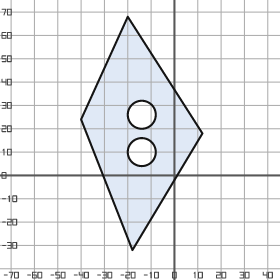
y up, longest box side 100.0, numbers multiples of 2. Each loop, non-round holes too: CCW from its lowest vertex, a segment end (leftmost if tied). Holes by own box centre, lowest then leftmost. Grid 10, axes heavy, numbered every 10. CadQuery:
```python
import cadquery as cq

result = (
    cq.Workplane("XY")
    .moveTo(-18.0, -32.0)
    .lineTo(12.0, 18.0)
    .lineTo(-20.0, 68.0)
    .lineTo(-40.0, 24.0)
    .close()
    .moveTo(-14.0, 10.0)
    .circle(6.0)
    .moveTo(-14.0, 26.0)
    .circle(6.0)
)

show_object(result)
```